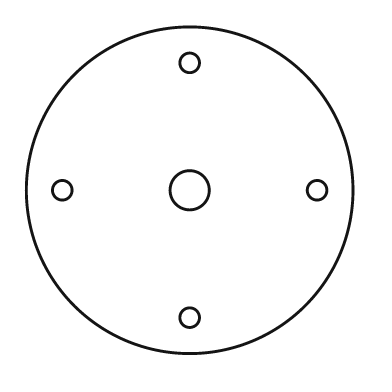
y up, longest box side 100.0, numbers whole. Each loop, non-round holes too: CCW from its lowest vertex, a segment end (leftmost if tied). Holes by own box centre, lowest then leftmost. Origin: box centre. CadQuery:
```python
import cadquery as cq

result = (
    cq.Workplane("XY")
    .moveTo(0.0, 0.0)
    .circle(50.0)
    .moveTo(0.0, -39.0)
    .circle(3.0)
    .moveTo(-39.0, 0.0)
    .circle(3.0)
    .moveTo(0.0, 0.0)
    .circle(6.0)
    .moveTo(39.0, 0.0)
    .circle(3.0)
    .moveTo(0.0, 39.0)
    .circle(3.0)
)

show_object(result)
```